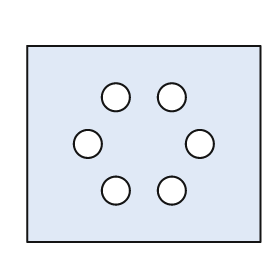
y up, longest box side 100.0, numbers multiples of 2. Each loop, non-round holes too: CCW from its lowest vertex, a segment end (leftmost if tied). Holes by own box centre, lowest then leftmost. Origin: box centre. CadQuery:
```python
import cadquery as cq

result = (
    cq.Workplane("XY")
    .moveTo(-50.0, -42.0)
    .lineTo(50.0, -42.0)
    .lineTo(50.0, 42.0)
    .lineTo(-50.0, 42.0)
    .close()
    .moveTo(-12.0, -20.0)
    .circle(6.0)
    .moveTo(12.0, -20.0)
    .circle(6.0)
    .moveTo(-24.0, 0.0)
    .circle(6.0)
    .moveTo(24.0, 0.0)
    .circle(6.0)
    .moveTo(-12.0, 20.0)
    .circle(6.0)
    .moveTo(12.0, 20.0)
    .circle(6.0)
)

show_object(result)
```